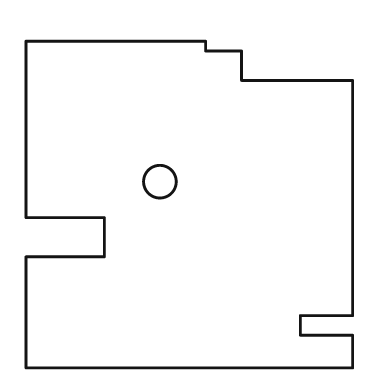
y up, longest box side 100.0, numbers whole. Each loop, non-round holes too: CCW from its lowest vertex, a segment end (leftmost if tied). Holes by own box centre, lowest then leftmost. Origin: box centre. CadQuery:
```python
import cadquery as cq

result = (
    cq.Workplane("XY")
    .moveTo(-50.0, -50.0)
    .lineTo(50.0, -50.0)
    .lineTo(50.0, -40.0)
    .lineTo(34.0, -40.0)
    .lineTo(34.0, -34.0)
    .lineTo(50.0, -34.0)
    .lineTo(50.0, 38.0)
    .lineTo(16.0, 38.0)
    .lineTo(16.0, 47.0)
    .lineTo(5.0, 47.0)
    .lineTo(5.0, 50.0)
    .lineTo(-50.0, 50.0)
    .lineTo(-50.0, -4.0)
    .lineTo(-26.0, -4.0)
    .lineTo(-26.0, -16.0)
    .lineTo(-50.0, -16.0)
    .close()
    .moveTo(-9.0, 7.0)
    .circle(5.0)
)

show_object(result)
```